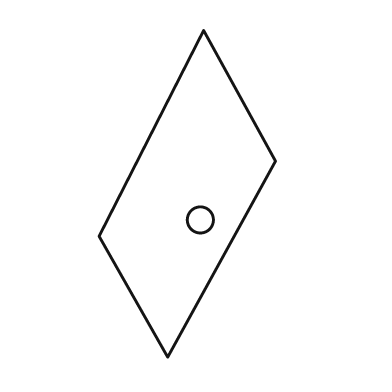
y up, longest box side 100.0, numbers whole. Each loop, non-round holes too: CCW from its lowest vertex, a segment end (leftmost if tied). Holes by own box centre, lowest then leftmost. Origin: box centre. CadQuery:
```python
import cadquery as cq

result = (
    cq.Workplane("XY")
    .moveTo(-6.0, -50.0)
    .lineTo(27.0, 10.0)
    .lineTo(5.0, 50.0)
    .lineTo(-27.0, -13.0)
    .close()
    .moveTo(4.0, -8.0)
    .circle(4.0)
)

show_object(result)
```